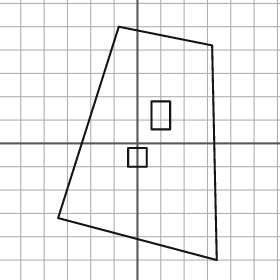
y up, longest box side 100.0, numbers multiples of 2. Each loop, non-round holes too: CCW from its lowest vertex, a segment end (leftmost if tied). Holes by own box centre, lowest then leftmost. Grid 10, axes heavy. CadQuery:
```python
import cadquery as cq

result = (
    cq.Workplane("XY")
    .moveTo(34.0, -50.0)
    .lineTo(32.0, 42.0)
    .lineTo(-8.0, 50.0)
    .lineTo(-34.0, -32.0)
    .close()
    .moveTo(-4.0, -10.0)
    .lineTo(4.0, -10.0)
    .lineTo(4.0, -2.0)
    .lineTo(-4.0, -2.0)
    .close()
    .moveTo(6.0, 6.0)
    .lineTo(14.0, 6.0)
    .lineTo(14.0, 18.0)
    .lineTo(6.0, 18.0)
    .close()
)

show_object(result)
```